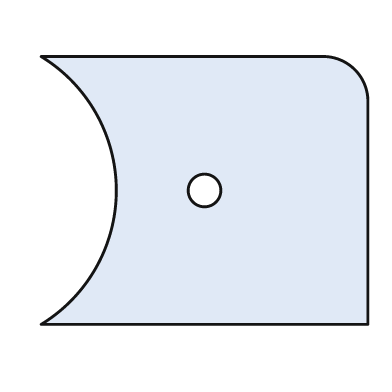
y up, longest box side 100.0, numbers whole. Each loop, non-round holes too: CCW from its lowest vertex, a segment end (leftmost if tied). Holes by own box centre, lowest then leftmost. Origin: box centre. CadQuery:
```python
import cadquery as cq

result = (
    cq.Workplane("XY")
    .moveTo(-50.0, -41.0)
    .lineTo(50.0, -41.0)
    .lineTo(50.0, 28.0)
    .threePointArc((46.0, 37.0), (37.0, 41.0))
    .lineTo(-50.0, 41.0)
    .threePointArc((-27.0, 0.0), (-50.0, -41.0))
    .close()
    .moveTo(0.0, 0.0)
    .circle(5.0)
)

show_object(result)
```